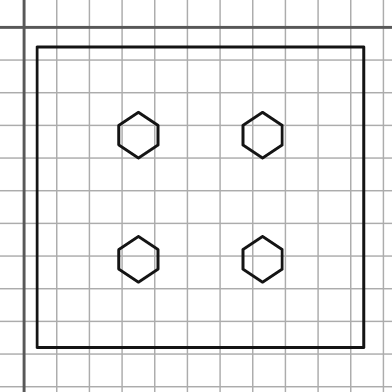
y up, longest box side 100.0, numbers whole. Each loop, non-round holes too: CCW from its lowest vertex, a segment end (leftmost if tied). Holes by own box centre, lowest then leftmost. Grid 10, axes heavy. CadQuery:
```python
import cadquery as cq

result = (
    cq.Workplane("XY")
    .moveTo(4.0, -98.0)
    .lineTo(104.0, -98.0)
    .lineTo(104.0, -6.0)
    .lineTo(4.0, -6.0)
    .close()
    .moveTo(35.0, -78.0)
    .lineTo(41.0, -74.0)
    .lineTo(41.0, -68.0)
    .lineTo(35.0, -64.0)
    .lineTo(29.0, -68.0)
    .lineTo(29.0, -74.0)
    .close()
    .moveTo(73.0, -78.0)
    .lineTo(79.0, -74.0)
    .lineTo(79.0, -68.0)
    .lineTo(73.0, -64.0)
    .lineTo(67.0, -68.0)
    .lineTo(67.0, -74.0)
    .close()
    .moveTo(35.0, -40.0)
    .lineTo(41.0, -36.0)
    .lineTo(41.0, -30.0)
    .lineTo(35.0, -26.0)
    .lineTo(29.0, -30.0)
    .lineTo(29.0, -36.0)
    .close()
    .moveTo(73.0, -40.0)
    .lineTo(79.0, -36.0)
    .lineTo(79.0, -30.0)
    .lineTo(73.0, -26.0)
    .lineTo(67.0, -30.0)
    .lineTo(67.0, -36.0)
    .close()
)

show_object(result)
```